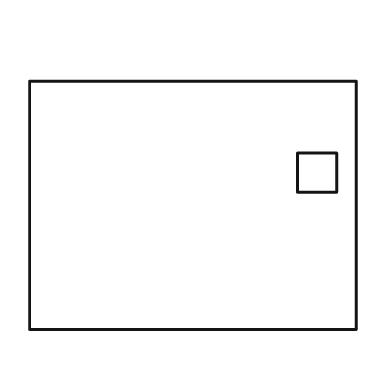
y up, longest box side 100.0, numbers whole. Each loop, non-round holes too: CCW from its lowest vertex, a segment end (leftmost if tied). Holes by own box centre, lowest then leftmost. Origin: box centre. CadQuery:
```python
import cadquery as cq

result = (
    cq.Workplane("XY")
    .moveTo(-50.0, -38.0)
    .lineTo(50.0, -38.0)
    .lineTo(50.0, 38.0)
    .lineTo(-50.0, 38.0)
    .close()
    .moveTo(32.0, 4.0)
    .lineTo(44.0, 4.0)
    .lineTo(44.0, 16.0)
    .lineTo(32.0, 16.0)
    .close()
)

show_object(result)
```